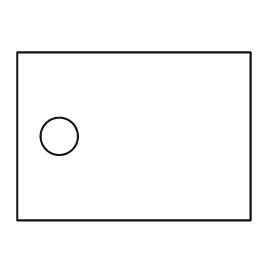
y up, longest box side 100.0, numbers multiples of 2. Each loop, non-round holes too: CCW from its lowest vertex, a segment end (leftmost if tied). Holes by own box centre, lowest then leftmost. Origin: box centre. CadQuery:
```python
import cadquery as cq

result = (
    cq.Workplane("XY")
    .moveTo(-50.0, -36.0)
    .lineTo(50.0, -36.0)
    .lineTo(50.0, 36.0)
    .lineTo(-50.0, 36.0)
    .close()
    .moveTo(-32.0, 0.0)
    .circle(8.0)
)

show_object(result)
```